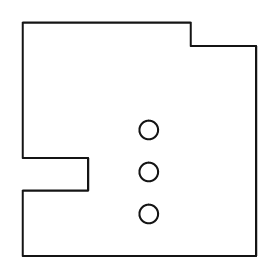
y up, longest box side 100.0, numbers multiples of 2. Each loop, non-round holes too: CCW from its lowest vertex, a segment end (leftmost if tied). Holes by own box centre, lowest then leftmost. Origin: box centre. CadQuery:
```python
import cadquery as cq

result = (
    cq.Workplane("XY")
    .moveTo(-50.0, -50.0)
    .lineTo(50.0, -50.0)
    .lineTo(50.0, 40.0)
    .lineTo(22.0, 40.0)
    .lineTo(22.0, 50.0)
    .lineTo(-50.0, 50.0)
    .lineTo(-50.0, -8.0)
    .lineTo(-22.0, -8.0)
    .lineTo(-22.0, -22.0)
    .lineTo(-50.0, -22.0)
    .close()
    .moveTo(4.0, -32.0)
    .circle(4.0)
    .moveTo(4.0, -14.0)
    .circle(4.0)
    .moveTo(4.0, 4.0)
    .circle(4.0)
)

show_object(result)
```